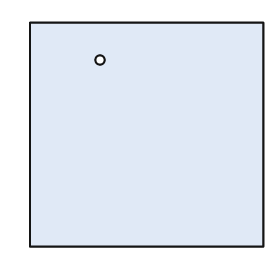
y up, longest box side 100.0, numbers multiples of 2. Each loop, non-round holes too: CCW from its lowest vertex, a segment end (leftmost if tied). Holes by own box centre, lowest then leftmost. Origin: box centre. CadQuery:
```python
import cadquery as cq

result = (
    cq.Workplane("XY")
    .moveTo(-50.0, -48.0)
    .lineTo(50.0, -48.0)
    .lineTo(50.0, 48.0)
    .lineTo(-50.0, 48.0)
    .close()
    .moveTo(-20.0, 32.0)
    .circle(2.0)
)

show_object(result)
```